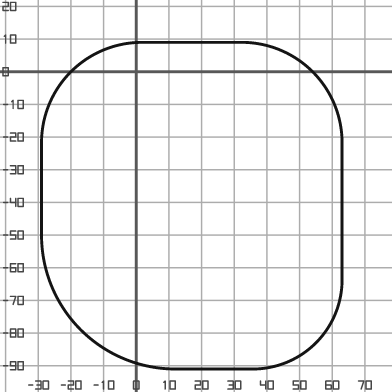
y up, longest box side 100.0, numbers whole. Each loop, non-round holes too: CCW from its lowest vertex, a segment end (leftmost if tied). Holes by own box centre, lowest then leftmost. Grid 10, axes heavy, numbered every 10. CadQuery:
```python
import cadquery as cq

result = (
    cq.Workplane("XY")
    .moveTo(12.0, -91.0)
    .lineTo(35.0, -91.0)
    .threePointArc((55.0, -83.0), (63.0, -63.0))
    .lineTo(63.0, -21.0)
    .threePointArc((54.0, 0.0), (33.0, 9.0))
    .lineTo(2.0, 9.0)
    .threePointArc((-20.0, 0.0), (-29.0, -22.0))
    .lineTo(-29.0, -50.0)
    .threePointArc((-17.0, -79.0), (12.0, -91.0))
    .close()
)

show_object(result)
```